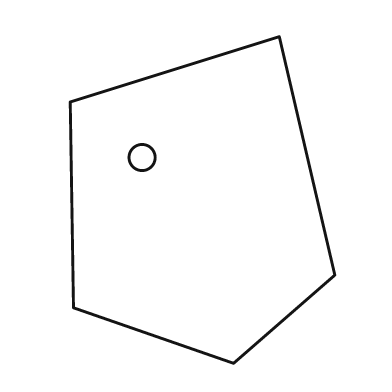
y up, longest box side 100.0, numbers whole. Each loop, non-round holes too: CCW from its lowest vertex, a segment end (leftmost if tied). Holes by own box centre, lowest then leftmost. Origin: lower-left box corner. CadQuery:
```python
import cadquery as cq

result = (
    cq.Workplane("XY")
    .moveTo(50.0, 0.0)
    .lineTo(81.0, 27.0)
    .lineTo(64.0, 100.0)
    .lineTo(0.0, 80.0)
    .lineTo(1.0, 17.0)
    .close()
    .moveTo(22.0, 63.0)
    .circle(4.0)
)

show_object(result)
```